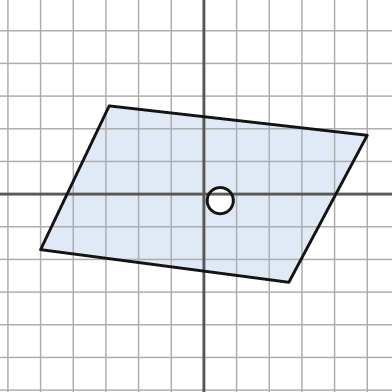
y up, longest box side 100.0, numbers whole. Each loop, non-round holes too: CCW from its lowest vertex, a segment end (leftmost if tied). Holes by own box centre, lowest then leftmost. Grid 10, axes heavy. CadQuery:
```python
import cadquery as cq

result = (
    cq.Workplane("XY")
    .moveTo(26.0, -27.0)
    .lineTo(50.0, 18.0)
    .lineTo(-29.0, 27.0)
    .lineTo(-50.0, -17.0)
    .close()
    .moveTo(5.0, -2.0)
    .circle(4.0)
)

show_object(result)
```